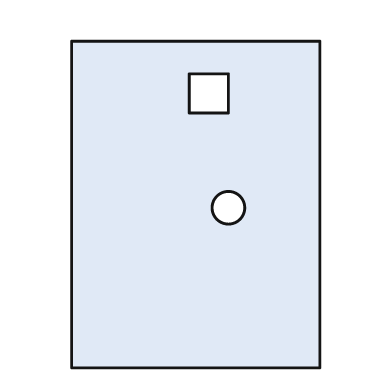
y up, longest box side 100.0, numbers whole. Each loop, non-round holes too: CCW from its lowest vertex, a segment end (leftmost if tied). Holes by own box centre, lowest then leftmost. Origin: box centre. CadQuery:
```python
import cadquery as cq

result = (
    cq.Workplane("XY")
    .moveTo(-38.0, -50.0)
    .lineTo(38.0, -50.0)
    .lineTo(38.0, 50.0)
    .lineTo(-38.0, 50.0)
    .close()
    .moveTo(10.0, -1.0)
    .circle(5.0)
    .moveTo(-2.0, 28.0)
    .lineTo(10.0, 28.0)
    .lineTo(10.0, 40.0)
    .lineTo(-2.0, 40.0)
    .close()
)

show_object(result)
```